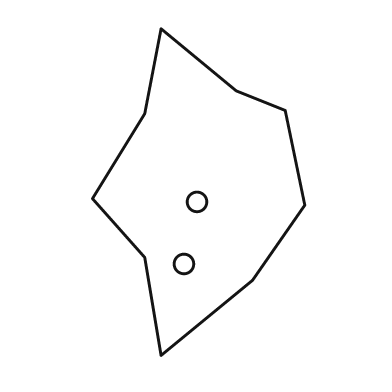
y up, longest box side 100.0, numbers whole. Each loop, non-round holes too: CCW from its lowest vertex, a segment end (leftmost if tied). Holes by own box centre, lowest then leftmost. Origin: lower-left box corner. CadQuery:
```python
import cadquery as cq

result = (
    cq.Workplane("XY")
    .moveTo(21.0, 0.0)
    .lineTo(49.0, 23.0)
    .lineTo(65.0, 46.0)
    .lineTo(59.0, 75.0)
    .lineTo(44.0, 81.0)
    .lineTo(21.0, 100.0)
    .lineTo(16.0, 74.0)
    .lineTo(0.0, 48.0)
    .lineTo(16.0, 30.0)
    .close()
    .moveTo(28.0, 28.0)
    .circle(3.0)
    .moveTo(32.0, 47.0)
    .circle(3.0)
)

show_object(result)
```